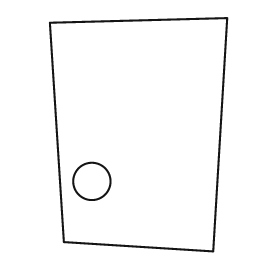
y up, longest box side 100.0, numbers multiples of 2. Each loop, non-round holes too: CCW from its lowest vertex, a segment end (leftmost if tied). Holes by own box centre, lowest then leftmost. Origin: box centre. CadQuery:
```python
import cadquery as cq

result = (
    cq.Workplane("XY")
    .moveTo(32.0, -50.0)
    .lineTo(38.0, 50.0)
    .lineTo(-38.0, 48.0)
    .lineTo(-32.0, -46.0)
    .close()
    .moveTo(-20.0, -20.0)
    .circle(8.0)
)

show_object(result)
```